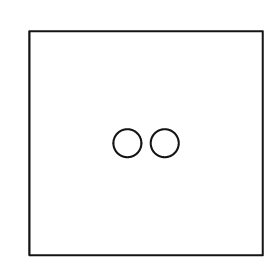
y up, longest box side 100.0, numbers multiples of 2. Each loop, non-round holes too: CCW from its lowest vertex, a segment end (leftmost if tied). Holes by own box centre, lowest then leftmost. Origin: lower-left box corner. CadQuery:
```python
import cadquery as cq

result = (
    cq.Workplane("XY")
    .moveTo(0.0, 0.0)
    .lineTo(100.0, 0.0)
    .lineTo(100.0, 96.0)
    .lineTo(0.0, 96.0)
    .close()
    .moveTo(42.0, 48.0)
    .circle(6.0)
    .moveTo(58.0, 48.0)
    .circle(6.0)
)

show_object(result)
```